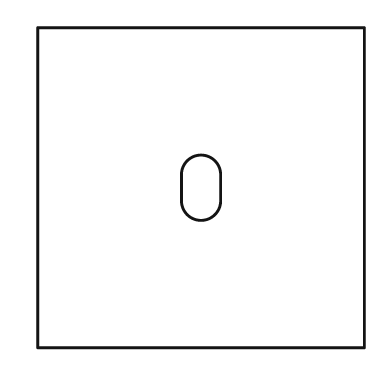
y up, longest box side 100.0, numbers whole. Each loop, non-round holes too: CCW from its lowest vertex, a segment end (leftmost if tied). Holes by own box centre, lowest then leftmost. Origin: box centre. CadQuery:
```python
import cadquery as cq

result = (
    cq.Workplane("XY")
    .moveTo(-50.0, -49.0)
    .lineTo(50.0, -49.0)
    .lineTo(50.0, 49.0)
    .lineTo(-50.0, 49.0)
    .close()
    .moveTo(-6.0, -4.0)
    .threePointArc((0.0, -10.0), (6.0, -4.0))
    .lineTo(6.0, 4.0)
    .threePointArc((0.0, 10.0), (-6.0, 4.0))
    .close()
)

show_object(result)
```